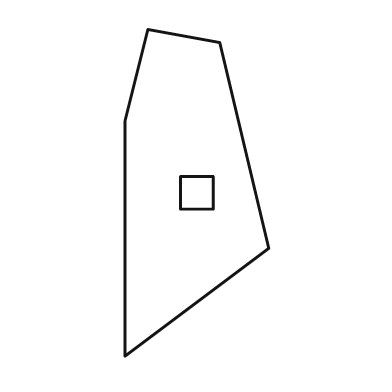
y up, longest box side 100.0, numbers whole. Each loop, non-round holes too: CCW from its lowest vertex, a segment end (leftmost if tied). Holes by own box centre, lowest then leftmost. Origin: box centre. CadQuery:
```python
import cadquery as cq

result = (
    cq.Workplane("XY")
    .moveTo(-22.0, -50.0)
    .lineTo(22.0, -17.0)
    .lineTo(7.0, 46.0)
    .lineTo(-15.0, 50.0)
    .lineTo(-22.0, 22.0)
    .close()
    .moveTo(-5.0, -5.0)
    .lineTo(5.0, -5.0)
    .lineTo(5.0, 5.0)
    .lineTo(-5.0, 5.0)
    .close()
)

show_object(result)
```